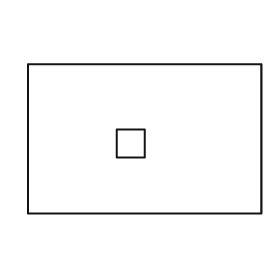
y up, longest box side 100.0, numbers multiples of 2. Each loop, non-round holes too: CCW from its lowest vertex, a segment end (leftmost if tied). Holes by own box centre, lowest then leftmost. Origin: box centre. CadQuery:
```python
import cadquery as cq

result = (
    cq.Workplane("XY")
    .moveTo(-50.0, -32.0)
    .lineTo(50.0, -32.0)
    .lineTo(50.0, 32.0)
    .lineTo(-50.0, 32.0)
    .close()
    .moveTo(-12.0, -8.0)
    .lineTo(0.0, -8.0)
    .lineTo(0.0, 4.0)
    .lineTo(-12.0, 4.0)
    .close()
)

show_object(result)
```